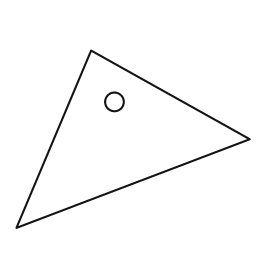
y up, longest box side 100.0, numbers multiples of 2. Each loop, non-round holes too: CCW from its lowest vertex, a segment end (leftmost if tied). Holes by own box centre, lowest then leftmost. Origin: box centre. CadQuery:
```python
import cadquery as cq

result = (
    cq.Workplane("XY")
    .moveTo(-50.0, -38.0)
    .lineTo(50.0, 0.0)
    .lineTo(-18.0, 38.0)
    .close()
    .moveTo(-8.0, 16.0)
    .circle(4.0)
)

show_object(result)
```